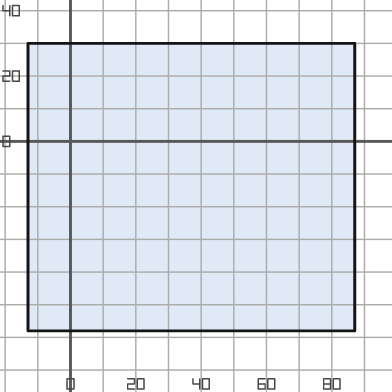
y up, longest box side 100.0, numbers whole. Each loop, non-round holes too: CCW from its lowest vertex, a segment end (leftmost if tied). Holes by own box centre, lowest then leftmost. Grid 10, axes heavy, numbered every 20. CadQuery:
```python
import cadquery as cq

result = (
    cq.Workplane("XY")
    .moveTo(-13.0, -58.0)
    .lineTo(87.0, -58.0)
    .lineTo(87.0, 30.0)
    .lineTo(-13.0, 30.0)
    .close()
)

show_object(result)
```